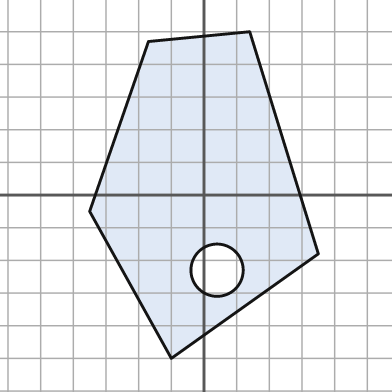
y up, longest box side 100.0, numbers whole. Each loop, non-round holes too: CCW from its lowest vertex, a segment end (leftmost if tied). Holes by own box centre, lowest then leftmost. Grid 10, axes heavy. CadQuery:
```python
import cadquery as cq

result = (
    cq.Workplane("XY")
    .moveTo(-10.0, -50.0)
    .lineTo(35.0, -18.0)
    .lineTo(14.0, 50.0)
    .lineTo(-17.0, 47.0)
    .lineTo(-35.0, -5.0)
    .close()
    .moveTo(4.0, -23.0)
    .circle(8.0)
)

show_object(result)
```